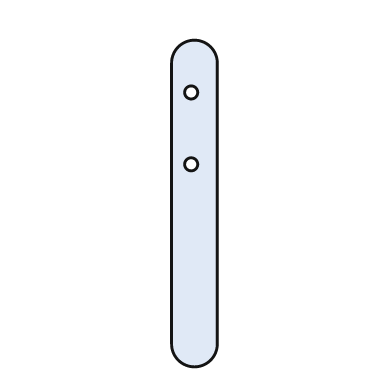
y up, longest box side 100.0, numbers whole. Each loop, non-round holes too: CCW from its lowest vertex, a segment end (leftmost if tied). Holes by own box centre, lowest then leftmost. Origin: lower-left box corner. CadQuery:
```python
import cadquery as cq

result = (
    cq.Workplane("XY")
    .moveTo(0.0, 7.0)
    .threePointArc((7.0, 0.0), (14.0, 7.0))
    .lineTo(14.0, 93.0)
    .threePointArc((7.0, 100.0), (0.0, 93.0))
    .close()
    .moveTo(6.0, 62.0)
    .circle(2.0)
    .moveTo(6.0, 84.0)
    .circle(2.0)
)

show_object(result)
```